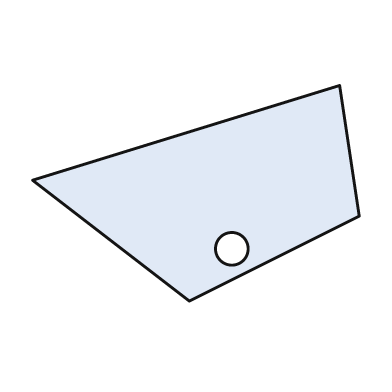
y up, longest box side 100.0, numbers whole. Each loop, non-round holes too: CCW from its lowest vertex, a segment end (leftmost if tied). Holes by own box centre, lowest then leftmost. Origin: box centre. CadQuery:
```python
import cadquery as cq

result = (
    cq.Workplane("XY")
    .moveTo(-2.0, -33.0)
    .lineTo(50.0, -7.0)
    .lineTo(44.0, 33.0)
    .lineTo(-50.0, 4.0)
    .close()
    .moveTo(11.0, -17.0)
    .circle(5.0)
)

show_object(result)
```